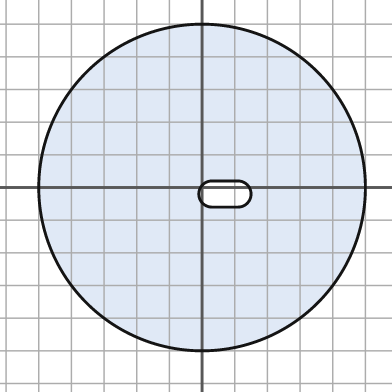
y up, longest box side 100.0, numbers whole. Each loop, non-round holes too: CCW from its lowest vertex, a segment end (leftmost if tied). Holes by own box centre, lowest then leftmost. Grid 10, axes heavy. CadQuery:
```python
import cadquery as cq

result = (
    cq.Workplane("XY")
    .moveTo(0.0, 0.0)
    .circle(50.0)
    .moveTo(3.0, -6.0)
    .lineTo(11.0, -6.0)
    .threePointArc((15.0, -2.0), (11.0, 2.0))
    .lineTo(3.0, 2.0)
    .threePointArc((-1.0, -2.0), (3.0, -6.0))
    .close()
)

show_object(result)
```